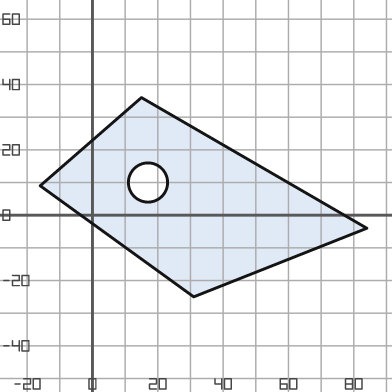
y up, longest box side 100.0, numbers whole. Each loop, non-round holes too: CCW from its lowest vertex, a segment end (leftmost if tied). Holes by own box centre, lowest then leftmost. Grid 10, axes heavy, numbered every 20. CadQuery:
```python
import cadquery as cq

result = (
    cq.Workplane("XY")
    .moveTo(31.0, -25.0)
    .lineTo(84.0, -4.0)
    .lineTo(15.0, 36.0)
    .lineTo(-16.0, 9.0)
    .close()
    .moveTo(17.0, 10.0)
    .circle(6.0)
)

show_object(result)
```